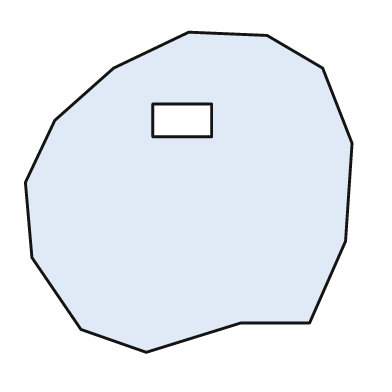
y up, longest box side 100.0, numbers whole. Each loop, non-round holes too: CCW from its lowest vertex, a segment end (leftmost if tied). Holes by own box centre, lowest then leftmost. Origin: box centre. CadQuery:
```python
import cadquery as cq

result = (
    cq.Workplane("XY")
    .moveTo(-13.0, -49.0)
    .lineTo(16.0, -40.0)
    .lineTo(37.0, -40.0)
    .lineTo(48.0, -15.0)
    .lineTo(50.0, 15.0)
    .lineTo(41.0, 38.0)
    .lineTo(24.0, 48.0)
    .lineTo(0.0, 49.0)
    .lineTo(-23.0, 38.0)
    .lineTo(-41.0, 22.0)
    .lineTo(-50.0, 3.0)
    .lineTo(-48.0, -20.0)
    .lineTo(-33.0, -42.0)
    .close()
    .moveTo(-11.0, 17.0)
    .lineTo(7.0, 17.0)
    .lineTo(7.0, 27.0)
    .lineTo(-11.0, 27.0)
    .close()
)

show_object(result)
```